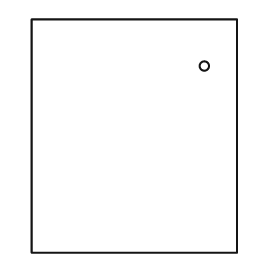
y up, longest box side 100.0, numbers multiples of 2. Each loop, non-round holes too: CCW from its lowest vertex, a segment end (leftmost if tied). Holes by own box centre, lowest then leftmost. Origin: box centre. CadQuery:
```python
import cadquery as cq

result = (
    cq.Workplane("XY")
    .moveTo(-44.0, -50.0)
    .lineTo(44.0, -50.0)
    .lineTo(44.0, 50.0)
    .lineTo(-44.0, 50.0)
    .close()
    .moveTo(30.0, 30.0)
    .circle(2.0)
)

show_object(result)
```